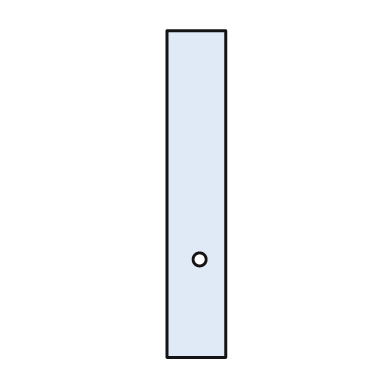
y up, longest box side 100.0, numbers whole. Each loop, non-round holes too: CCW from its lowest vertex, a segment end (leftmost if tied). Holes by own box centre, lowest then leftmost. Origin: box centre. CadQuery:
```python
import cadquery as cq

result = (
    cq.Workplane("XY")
    .moveTo(-9.0, -50.0)
    .lineTo(9.0, -50.0)
    .lineTo(9.0, 50.0)
    .lineTo(-9.0, 50.0)
    .close()
    .moveTo(1.0, -20.0)
    .circle(2.0)
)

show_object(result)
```